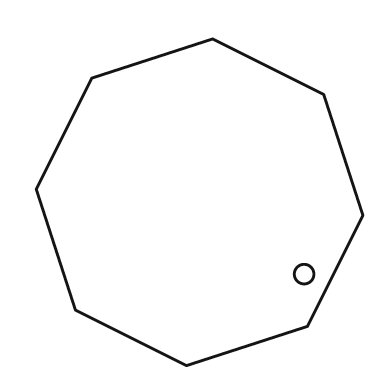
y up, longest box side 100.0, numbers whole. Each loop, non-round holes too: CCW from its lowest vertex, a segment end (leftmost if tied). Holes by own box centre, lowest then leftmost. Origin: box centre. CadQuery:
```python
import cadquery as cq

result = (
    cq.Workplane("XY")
    .moveTo(-4.0, -50.0)
    .lineTo(33.0, -38.0)
    .lineTo(50.0, -4.0)
    .lineTo(38.0, 33.0)
    .lineTo(4.0, 50.0)
    .lineTo(-33.0, 38.0)
    .lineTo(-50.0, 4.0)
    .lineTo(-38.0, -33.0)
    .close()
    .moveTo(32.0, -22.0)
    .circle(3.0)
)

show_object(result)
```